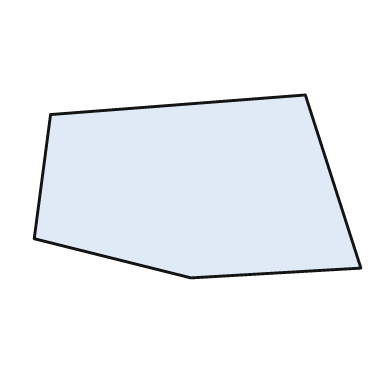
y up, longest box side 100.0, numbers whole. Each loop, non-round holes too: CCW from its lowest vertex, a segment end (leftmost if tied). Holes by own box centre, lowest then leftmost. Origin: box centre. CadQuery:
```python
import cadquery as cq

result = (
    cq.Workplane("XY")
    .moveTo(-2.0, -28.0)
    .lineTo(50.0, -25.0)
    .lineTo(33.0, 28.0)
    .lineTo(-45.0, 22.0)
    .lineTo(-50.0, -16.0)
    .close()
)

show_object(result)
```